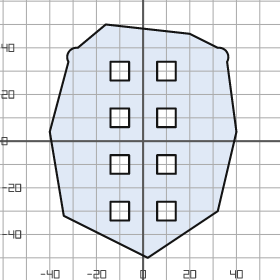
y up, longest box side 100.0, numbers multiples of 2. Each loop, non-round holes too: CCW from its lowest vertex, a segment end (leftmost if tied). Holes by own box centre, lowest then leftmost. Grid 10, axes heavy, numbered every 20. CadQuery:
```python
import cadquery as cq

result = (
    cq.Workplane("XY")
    .moveTo(2.0, -50.0)
    .lineTo(32.0, -30.0)
    .lineTo(40.0, 4.0)
    .lineTo(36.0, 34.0)
    .threePointArc((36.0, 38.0), (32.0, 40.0))
    .lineTo(20.0, 46.0)
    .lineTo(-16.0, 50.0)
    .lineTo(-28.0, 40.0)
    .threePointArc((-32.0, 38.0), (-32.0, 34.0))
    .lineTo(-40.0, 4.0)
    .lineTo(-34.0, -32.0)
    .close()
    .moveTo(-14.0, -34.0)
    .lineTo(-6.0, -34.0)
    .lineTo(-6.0, -26.0)
    .lineTo(-14.0, -26.0)
    .close()
    .moveTo(6.0, -34.0)
    .lineTo(14.0, -34.0)
    .lineTo(14.0, -26.0)
    .lineTo(6.0, -26.0)
    .close()
    .moveTo(-14.0, -14.0)
    .lineTo(-6.0, -14.0)
    .lineTo(-6.0, -6.0)
    .lineTo(-14.0, -6.0)
    .close()
    .moveTo(6.0, -14.0)
    .lineTo(14.0, -14.0)
    .lineTo(14.0, -6.0)
    .lineTo(6.0, -6.0)
    .close()
    .moveTo(-14.0, 6.0)
    .lineTo(-6.0, 6.0)
    .lineTo(-6.0, 14.0)
    .lineTo(-14.0, 14.0)
    .close()
    .moveTo(6.0, 6.0)
    .lineTo(14.0, 6.0)
    .lineTo(14.0, 14.0)
    .lineTo(6.0, 14.0)
    .close()
    .moveTo(-14.0, 26.0)
    .lineTo(-6.0, 26.0)
    .lineTo(-6.0, 34.0)
    .lineTo(-14.0, 34.0)
    .close()
    .moveTo(6.0, 26.0)
    .lineTo(14.0, 26.0)
    .lineTo(14.0, 34.0)
    .lineTo(6.0, 34.0)
    .close()
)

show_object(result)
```